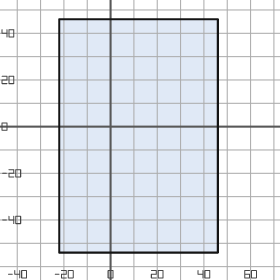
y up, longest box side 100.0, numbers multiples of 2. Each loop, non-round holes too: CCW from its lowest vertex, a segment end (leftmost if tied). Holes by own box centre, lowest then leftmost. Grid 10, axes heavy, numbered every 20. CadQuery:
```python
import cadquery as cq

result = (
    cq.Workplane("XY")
    .moveTo(-22.0, -54.0)
    .lineTo(46.0, -54.0)
    .lineTo(46.0, 46.0)
    .lineTo(-22.0, 46.0)
    .close()
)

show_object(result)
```